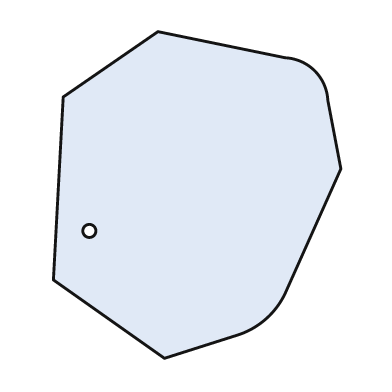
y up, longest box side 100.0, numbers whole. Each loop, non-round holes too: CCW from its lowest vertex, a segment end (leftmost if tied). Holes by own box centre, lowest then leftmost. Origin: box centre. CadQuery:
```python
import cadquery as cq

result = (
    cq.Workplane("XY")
    .moveTo(-10.0, -50.0)
    .lineTo(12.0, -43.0)
    .threePointArc((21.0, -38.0), (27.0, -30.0))
    .lineTo(44.0, 8.0)
    .lineTo(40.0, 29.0)
    .threePointArc((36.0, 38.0), (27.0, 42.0))
    .lineTo(-12.0, 50.0)
    .lineTo(-41.0, 30.0)
    .lineTo(-44.0, -26.0)
    .close()
    .moveTo(-33.0, -11.0)
    .circle(2.0)
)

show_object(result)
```